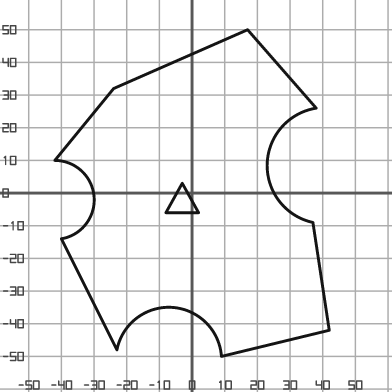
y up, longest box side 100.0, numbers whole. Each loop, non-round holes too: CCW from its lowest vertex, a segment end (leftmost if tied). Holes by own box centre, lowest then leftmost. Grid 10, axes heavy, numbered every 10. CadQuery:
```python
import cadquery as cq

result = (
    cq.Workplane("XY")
    .moveTo(9.0, -50.0)
    .lineTo(42.0, -42.0)
    .lineTo(37.0, -9.0)
    .threePointArc((23.0, 9.0), (38.0, 26.0))
    .lineTo(17.0, 50.0)
    .lineTo(-24.0, 32.0)
    .lineTo(-42.0, 10.0)
    .threePointArc((-30.0, -1.0), (-40.0, -14.0))
    .lineTo(-23.0, -48.0)
    .threePointArc((-6.0, -35.0), (9.0, -50.0))
    .close()
    .moveTo(-8.0, -6.0)
    .lineTo(2.0, -6.0)
    .lineTo(-3.0, 3.0)
    .close()
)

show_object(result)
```